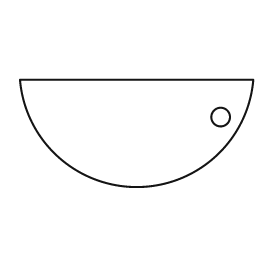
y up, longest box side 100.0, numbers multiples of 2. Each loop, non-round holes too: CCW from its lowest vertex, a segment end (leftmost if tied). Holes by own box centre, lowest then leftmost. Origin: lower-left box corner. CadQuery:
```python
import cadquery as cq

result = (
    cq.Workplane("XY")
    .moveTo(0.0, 46.0)
    .threePointArc((50.0, 0.0), (100.0, 46.0))
    .close()
    .moveTo(86.0, 30.0)
    .circle(4.0)
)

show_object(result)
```